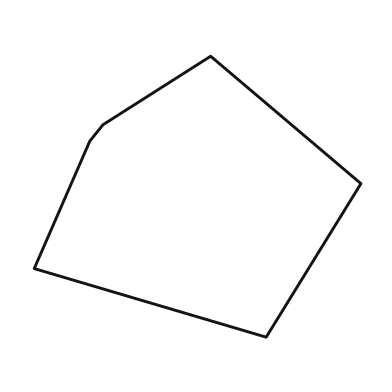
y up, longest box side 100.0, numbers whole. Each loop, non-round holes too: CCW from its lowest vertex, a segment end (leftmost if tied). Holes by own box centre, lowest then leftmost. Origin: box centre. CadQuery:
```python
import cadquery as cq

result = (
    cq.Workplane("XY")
    .moveTo(21.0, -43.0)
    .lineTo(50.0, 4.0)
    .lineTo(4.0, 43.0)
    .lineTo(-29.0, 22.0)
    .lineTo(-33.0, 17.0)
    .lineTo(-50.0, -22.0)
    .close()
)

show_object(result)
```